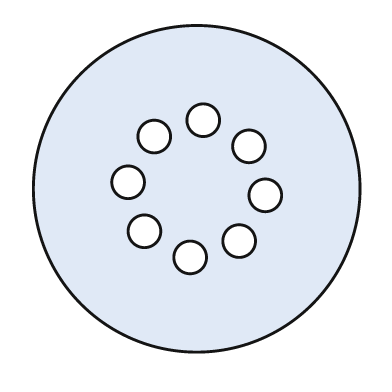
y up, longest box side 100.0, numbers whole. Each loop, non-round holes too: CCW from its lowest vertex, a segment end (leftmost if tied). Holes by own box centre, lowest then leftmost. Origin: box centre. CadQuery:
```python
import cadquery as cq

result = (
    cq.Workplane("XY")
    .moveTo(0.0, 0.0)
    .circle(50.0)
    .moveTo(-2.0, -21.0)
    .circle(5.0)
    .moveTo(13.0, -16.0)
    .circle(5.0)
    .moveTo(-16.0, -13.0)
    .circle(5.0)
    .moveTo(21.0, -2.0)
    .circle(5.0)
    .moveTo(-21.0, 2.0)
    .circle(5.0)
    .moveTo(16.0, 13.0)
    .circle(5.0)
    .moveTo(-13.0, 16.0)
    .circle(5.0)
    .moveTo(2.0, 21.0)
    .circle(5.0)
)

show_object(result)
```